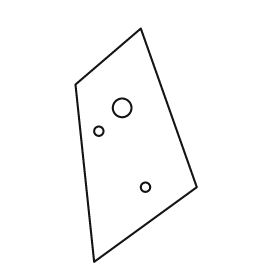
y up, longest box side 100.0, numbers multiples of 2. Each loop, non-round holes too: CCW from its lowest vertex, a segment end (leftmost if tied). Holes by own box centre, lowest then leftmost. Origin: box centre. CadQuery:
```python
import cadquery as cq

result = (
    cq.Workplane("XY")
    .moveTo(-18.0, -50.0)
    .lineTo(26.0, -18.0)
    .lineTo(2.0, 50.0)
    .lineTo(-26.0, 26.0)
    .close()
    .moveTo(4.0, -18.0)
    .circle(2.0)
    .moveTo(-16.0, 6.0)
    .circle(2.0)
    .moveTo(-6.0, 16.0)
    .circle(4.0)
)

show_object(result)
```